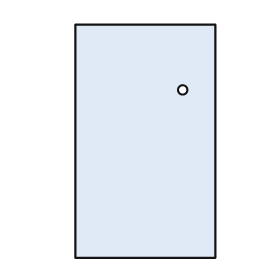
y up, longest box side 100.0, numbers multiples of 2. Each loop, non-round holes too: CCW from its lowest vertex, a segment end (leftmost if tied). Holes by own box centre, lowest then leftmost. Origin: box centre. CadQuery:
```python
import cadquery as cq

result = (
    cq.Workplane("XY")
    .moveTo(-30.0, -50.0)
    .lineTo(30.0, -50.0)
    .lineTo(30.0, 50.0)
    .lineTo(-30.0, 50.0)
    .close()
    .moveTo(16.0, 22.0)
    .circle(2.0)
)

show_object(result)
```